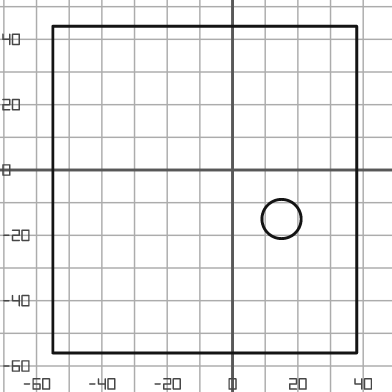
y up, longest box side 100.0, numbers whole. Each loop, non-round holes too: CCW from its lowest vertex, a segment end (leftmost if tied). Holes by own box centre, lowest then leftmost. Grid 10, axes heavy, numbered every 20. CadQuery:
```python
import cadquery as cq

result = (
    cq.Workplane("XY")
    .moveTo(-55.0, -56.0)
    .lineTo(38.0, -56.0)
    .lineTo(38.0, 44.0)
    .lineTo(-55.0, 44.0)
    .close()
    .moveTo(15.0, -15.0)
    .circle(6.0)
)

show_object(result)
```